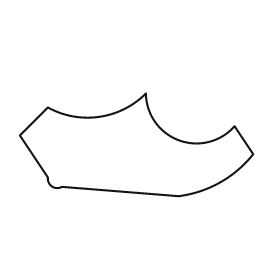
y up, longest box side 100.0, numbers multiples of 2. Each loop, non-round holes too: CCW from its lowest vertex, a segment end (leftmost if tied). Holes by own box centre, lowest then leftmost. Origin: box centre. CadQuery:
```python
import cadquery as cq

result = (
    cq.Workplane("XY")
    .moveTo(18.0, -22.0)
    .threePointArc((36.0, -16.0), (50.0, -4.0))
    .lineTo(42.0, 8.0)
    .threePointArc((18.0, 2.0), (4.0, 22.0))
    .threePointArc((-16.0, 12.0), (-38.0, 16.0))
    .lineTo(-50.0, 4.0)
    .lineTo(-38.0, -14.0)
    .threePointArc((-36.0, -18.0), (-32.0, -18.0))
    .close()
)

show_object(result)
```